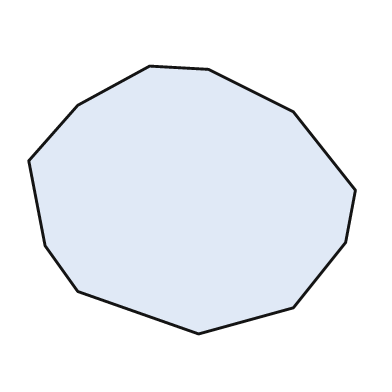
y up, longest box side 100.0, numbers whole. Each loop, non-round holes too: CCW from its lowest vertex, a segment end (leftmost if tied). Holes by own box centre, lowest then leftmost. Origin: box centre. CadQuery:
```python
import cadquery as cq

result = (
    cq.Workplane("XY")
    .moveTo(2.0, -41.0)
    .lineTo(31.0, -33.0)
    .lineTo(47.0, -13.0)
    .lineTo(50.0, 3.0)
    .lineTo(31.0, 27.0)
    .lineTo(5.0, 40.0)
    .lineTo(-13.0, 41.0)
    .lineTo(-35.0, 29.0)
    .lineTo(-50.0, 12.0)
    .lineTo(-45.0, -14.0)
    .lineTo(-35.0, -28.0)
    .close()
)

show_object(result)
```